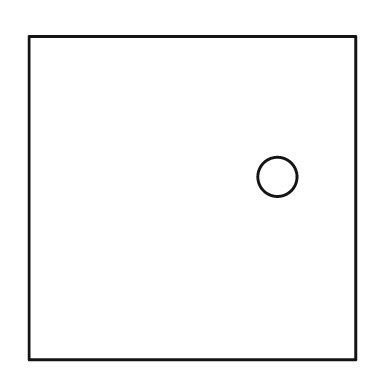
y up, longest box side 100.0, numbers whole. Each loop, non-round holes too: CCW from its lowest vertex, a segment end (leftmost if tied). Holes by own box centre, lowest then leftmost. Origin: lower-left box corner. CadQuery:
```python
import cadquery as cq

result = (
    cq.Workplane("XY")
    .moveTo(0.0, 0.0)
    .lineTo(100.0, 0.0)
    .lineTo(100.0, 99.0)
    .lineTo(0.0, 99.0)
    .close()
    .moveTo(76.0, 56.0)
    .circle(6.0)
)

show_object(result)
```